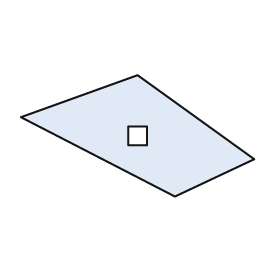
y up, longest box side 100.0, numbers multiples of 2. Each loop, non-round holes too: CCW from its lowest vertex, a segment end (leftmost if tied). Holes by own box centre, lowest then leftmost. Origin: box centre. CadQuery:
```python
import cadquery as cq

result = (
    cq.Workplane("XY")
    .moveTo(16.0, -26.0)
    .lineTo(50.0, -10.0)
    .lineTo(0.0, 26.0)
    .lineTo(-50.0, 8.0)
    .close()
    .moveTo(-4.0, -4.0)
    .lineTo(4.0, -4.0)
    .lineTo(4.0, 4.0)
    .lineTo(-4.0, 4.0)
    .close()
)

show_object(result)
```